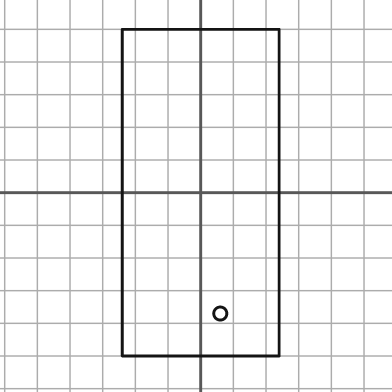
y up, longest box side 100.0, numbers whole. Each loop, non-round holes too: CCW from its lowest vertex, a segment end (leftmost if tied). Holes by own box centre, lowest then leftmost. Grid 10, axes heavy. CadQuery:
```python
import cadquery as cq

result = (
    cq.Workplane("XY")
    .moveTo(-24.0, -50.0)
    .lineTo(24.0, -50.0)
    .lineTo(24.0, 50.0)
    .lineTo(-24.0, 50.0)
    .close()
    .moveTo(6.0, -37.0)
    .circle(2.0)
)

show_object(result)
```